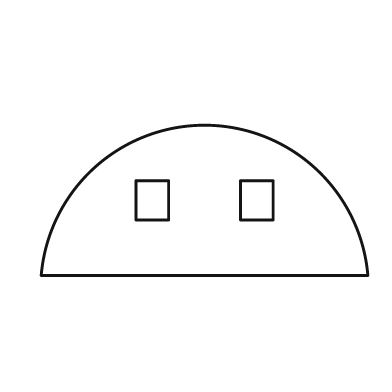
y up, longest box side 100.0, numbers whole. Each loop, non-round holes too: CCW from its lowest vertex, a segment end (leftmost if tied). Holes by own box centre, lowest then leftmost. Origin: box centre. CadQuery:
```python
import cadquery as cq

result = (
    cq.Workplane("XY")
    .moveTo(-50.0, -23.0)
    .lineTo(50.0, -23.0)
    .threePointArc((0.0, 23.0), (-50.0, -23.0))
    .close()
    .moveTo(-21.0, -6.0)
    .lineTo(-11.0, -6.0)
    .lineTo(-11.0, 6.0)
    .lineTo(-21.0, 6.0)
    .close()
    .moveTo(11.0, -6.0)
    .lineTo(21.0, -6.0)
    .lineTo(21.0, 6.0)
    .lineTo(11.0, 6.0)
    .close()
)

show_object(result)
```